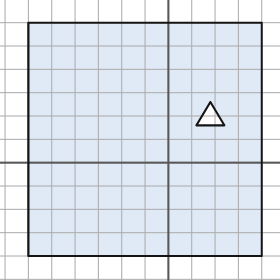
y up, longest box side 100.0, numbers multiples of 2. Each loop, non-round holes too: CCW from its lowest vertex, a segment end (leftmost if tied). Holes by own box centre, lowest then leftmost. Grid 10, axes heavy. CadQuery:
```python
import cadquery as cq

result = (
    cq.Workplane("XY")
    .moveTo(-60.0, -40.0)
    .lineTo(40.0, -40.0)
    .lineTo(40.0, 60.0)
    .lineTo(-60.0, 60.0)
    .close()
    .moveTo(12.0, 16.0)
    .lineTo(24.0, 16.0)
    .lineTo(18.0, 26.0)
    .close()
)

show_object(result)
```